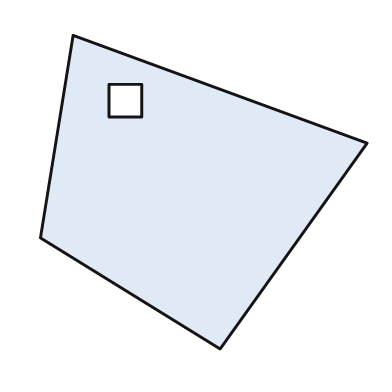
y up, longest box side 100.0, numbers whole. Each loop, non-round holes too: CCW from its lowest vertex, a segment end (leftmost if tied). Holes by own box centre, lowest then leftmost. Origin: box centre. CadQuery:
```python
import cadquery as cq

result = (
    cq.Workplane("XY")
    .moveTo(5.0, -48.0)
    .lineTo(50.0, 15.0)
    .lineTo(-40.0, 48.0)
    .lineTo(-50.0, -14.0)
    .close()
    .moveTo(-29.0, 23.0)
    .lineTo(-19.0, 23.0)
    .lineTo(-19.0, 33.0)
    .lineTo(-29.0, 33.0)
    .close()
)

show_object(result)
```